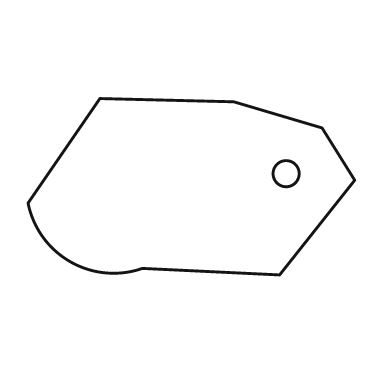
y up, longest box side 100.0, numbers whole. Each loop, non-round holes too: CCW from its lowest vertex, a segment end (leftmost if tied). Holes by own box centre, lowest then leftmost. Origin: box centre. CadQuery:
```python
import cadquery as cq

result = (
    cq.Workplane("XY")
    .moveTo(27.0, -27.0)
    .lineTo(50.0, 2.0)
    .lineTo(40.0, 18.0)
    .lineTo(13.0, 26.0)
    .lineTo(-28.0, 27.0)
    .lineTo(-50.0, -5.0)
    .threePointArc((-37.0, -23.0), (-15.0, -25.0))
    .close()
    .moveTo(29.0, 4.0)
    .circle(4.0)
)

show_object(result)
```